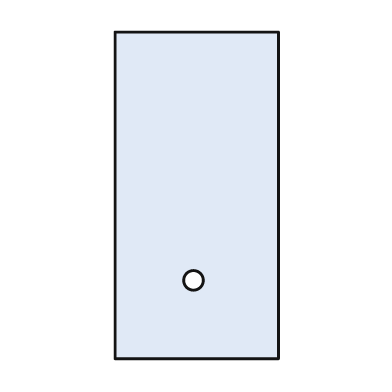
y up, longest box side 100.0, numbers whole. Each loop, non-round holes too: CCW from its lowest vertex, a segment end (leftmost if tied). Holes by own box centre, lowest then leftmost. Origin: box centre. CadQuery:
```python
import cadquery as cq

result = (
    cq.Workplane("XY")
    .moveTo(-25.0, -50.0)
    .lineTo(25.0, -50.0)
    .lineTo(25.0, 50.0)
    .lineTo(-25.0, 50.0)
    .close()
    .moveTo(-1.0, -26.0)
    .circle(3.0)
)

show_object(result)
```